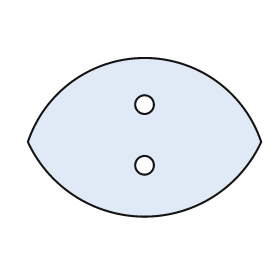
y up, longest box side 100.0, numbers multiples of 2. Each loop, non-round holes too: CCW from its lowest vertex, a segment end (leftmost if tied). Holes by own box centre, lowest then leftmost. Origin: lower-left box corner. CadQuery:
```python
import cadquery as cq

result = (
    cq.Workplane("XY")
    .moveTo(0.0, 32.0)
    .threePointArc((50.0, 0.0), (100.0, 32.0))
    .threePointArc((50.0, 68.0), (0.0, 32.0))
    .close()
    .moveTo(50.0, 22.0)
    .circle(4.0)
    .moveTo(50.0, 48.0)
    .circle(4.0)
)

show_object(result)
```